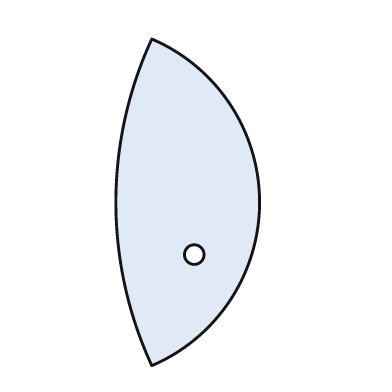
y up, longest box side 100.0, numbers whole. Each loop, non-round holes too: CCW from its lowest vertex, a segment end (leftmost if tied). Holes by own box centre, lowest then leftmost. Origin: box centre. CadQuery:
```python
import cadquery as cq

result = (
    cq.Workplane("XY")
    .moveTo(-11.0, -50.0)
    .threePointArc((22.0, 0.0), (-11.0, 50.0))
    .threePointArc((-22.0, 0.0), (-11.0, -50.0))
    .close()
    .moveTo(2.0, -16.0)
    .circle(3.0)
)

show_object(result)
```